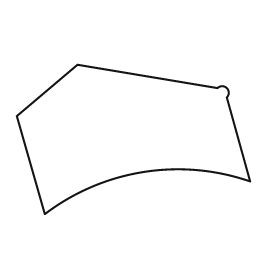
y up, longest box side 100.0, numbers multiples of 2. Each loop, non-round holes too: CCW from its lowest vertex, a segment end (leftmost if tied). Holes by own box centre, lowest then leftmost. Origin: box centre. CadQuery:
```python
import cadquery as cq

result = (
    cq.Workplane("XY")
    .moveTo(-38.0, -32.0)
    .threePointArc((4.0, -14.0), (50.0, -18.0))
    .lineTo(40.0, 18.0)
    .threePointArc((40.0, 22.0), (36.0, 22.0))
    .lineTo(-24.0, 32.0)
    .lineTo(-50.0, 10.0)
    .close()
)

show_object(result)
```